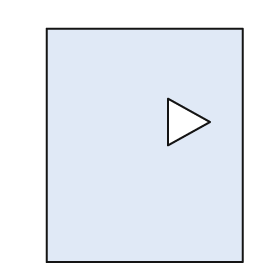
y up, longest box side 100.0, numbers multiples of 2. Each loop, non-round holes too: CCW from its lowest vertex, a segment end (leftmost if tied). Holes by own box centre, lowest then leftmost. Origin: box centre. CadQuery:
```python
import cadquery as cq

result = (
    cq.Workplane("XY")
    .moveTo(-42.0, -50.0)
    .lineTo(42.0, -50.0)
    .lineTo(42.0, 50.0)
    .lineTo(-42.0, 50.0)
    .close()
    .moveTo(10.0, 0.0)
    .lineTo(28.0, 10.0)
    .lineTo(10.0, 20.0)
    .close()
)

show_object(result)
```